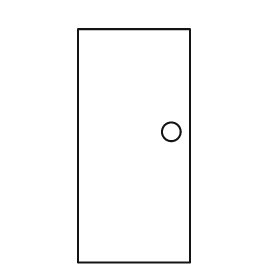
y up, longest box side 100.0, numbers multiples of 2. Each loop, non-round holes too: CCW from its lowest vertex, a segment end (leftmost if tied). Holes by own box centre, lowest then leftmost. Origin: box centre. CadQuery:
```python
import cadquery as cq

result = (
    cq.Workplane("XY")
    .moveTo(-24.0, -50.0)
    .lineTo(24.0, -50.0)
    .lineTo(24.0, 50.0)
    .lineTo(-24.0, 50.0)
    .close()
    .moveTo(16.0, 6.0)
    .circle(4.0)
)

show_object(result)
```